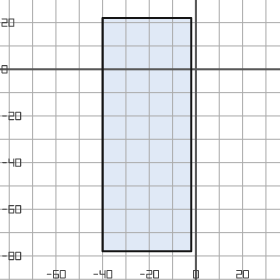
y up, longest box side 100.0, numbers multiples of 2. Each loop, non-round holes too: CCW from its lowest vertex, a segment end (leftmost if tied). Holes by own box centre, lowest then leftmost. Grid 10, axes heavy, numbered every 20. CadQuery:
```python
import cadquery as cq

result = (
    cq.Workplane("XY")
    .moveTo(-40.0, -78.0)
    .lineTo(-2.0, -78.0)
    .lineTo(-2.0, 22.0)
    .lineTo(-40.0, 22.0)
    .close()
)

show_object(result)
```